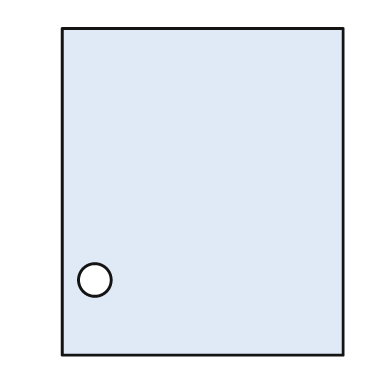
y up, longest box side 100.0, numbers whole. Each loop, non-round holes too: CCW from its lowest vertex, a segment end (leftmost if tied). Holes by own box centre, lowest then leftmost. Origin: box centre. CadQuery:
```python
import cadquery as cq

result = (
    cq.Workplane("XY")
    .moveTo(-43.0, -50.0)
    .lineTo(43.0, -50.0)
    .lineTo(43.0, 50.0)
    .lineTo(-43.0, 50.0)
    .close()
    .moveTo(-33.0, -27.0)
    .circle(5.0)
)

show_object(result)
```